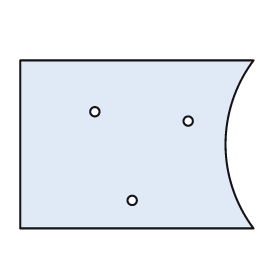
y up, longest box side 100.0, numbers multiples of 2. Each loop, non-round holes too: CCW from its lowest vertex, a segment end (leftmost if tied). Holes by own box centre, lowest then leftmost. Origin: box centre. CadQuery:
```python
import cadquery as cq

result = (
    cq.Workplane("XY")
    .moveTo(-50.0, -36.0)
    .lineTo(50.0, -36.0)
    .threePointArc((38.0, 0.0), (50.0, 36.0))
    .lineTo(-50.0, 36.0)
    .close()
    .moveTo(-2.0, -24.0)
    .circle(2.0)
    .moveTo(22.0, 10.0)
    .circle(2.0)
    .moveTo(-18.0, 14.0)
    .circle(2.0)
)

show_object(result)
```